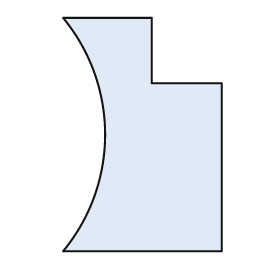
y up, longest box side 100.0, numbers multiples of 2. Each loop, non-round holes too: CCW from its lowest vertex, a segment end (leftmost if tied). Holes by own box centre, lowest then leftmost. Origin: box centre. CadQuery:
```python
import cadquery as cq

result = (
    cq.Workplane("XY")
    .moveTo(-34.0, -50.0)
    .lineTo(34.0, -50.0)
    .lineTo(34.0, 22.0)
    .lineTo(4.0, 22.0)
    .lineTo(4.0, 50.0)
    .lineTo(-34.0, 50.0)
    .threePointArc((-16.0, 0.0), (-34.0, -50.0))
    .close()
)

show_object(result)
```